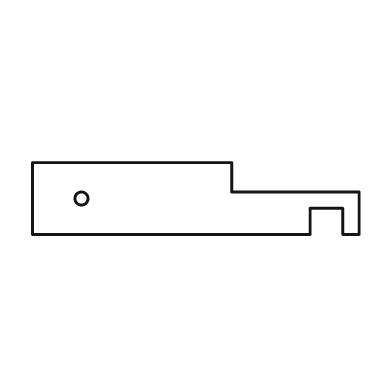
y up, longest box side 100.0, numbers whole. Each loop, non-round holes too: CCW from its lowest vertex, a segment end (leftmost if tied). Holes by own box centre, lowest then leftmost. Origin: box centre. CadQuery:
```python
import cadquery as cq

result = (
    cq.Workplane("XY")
    .moveTo(-50.0, -11.0)
    .lineTo(35.0, -11.0)
    .lineTo(35.0, -3.0)
    .lineTo(45.0, -3.0)
    .lineTo(45.0, -11.0)
    .lineTo(50.0, -11.0)
    .lineTo(50.0, 2.0)
    .lineTo(11.0, 2.0)
    .lineTo(11.0, 11.0)
    .lineTo(-50.0, 11.0)
    .close()
    .moveTo(-35.0, 0.0)
    .circle(2.0)
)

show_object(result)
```